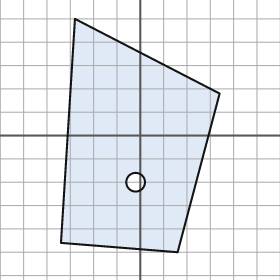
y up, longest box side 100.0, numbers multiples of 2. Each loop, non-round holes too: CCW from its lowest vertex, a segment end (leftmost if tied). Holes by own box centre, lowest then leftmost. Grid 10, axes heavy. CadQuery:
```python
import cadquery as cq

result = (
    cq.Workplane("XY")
    .moveTo(16.0, -50.0)
    .lineTo(34.0, 18.0)
    .lineTo(-28.0, 50.0)
    .lineTo(-34.0, -46.0)
    .close()
    .moveTo(-2.0, -20.0)
    .circle(4.0)
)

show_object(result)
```